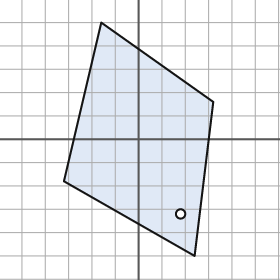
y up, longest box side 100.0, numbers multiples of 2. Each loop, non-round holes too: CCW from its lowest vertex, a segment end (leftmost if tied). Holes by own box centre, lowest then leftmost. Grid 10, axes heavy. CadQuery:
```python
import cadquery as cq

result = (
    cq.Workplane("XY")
    .moveTo(24.0, -50.0)
    .lineTo(32.0, 16.0)
    .lineTo(-16.0, 50.0)
    .lineTo(-32.0, -18.0)
    .close()
    .moveTo(18.0, -32.0)
    .circle(2.0)
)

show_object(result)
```